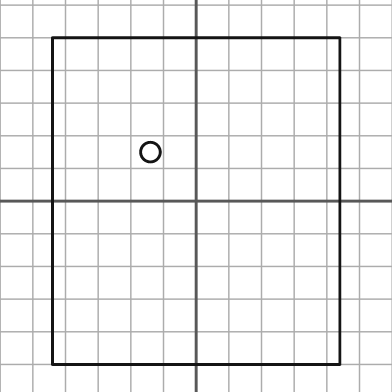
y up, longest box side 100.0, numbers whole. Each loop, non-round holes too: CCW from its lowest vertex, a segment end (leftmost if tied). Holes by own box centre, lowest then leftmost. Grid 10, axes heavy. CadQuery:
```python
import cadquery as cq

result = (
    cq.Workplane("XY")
    .moveTo(-44.0, -50.0)
    .lineTo(44.0, -50.0)
    .lineTo(44.0, 50.0)
    .lineTo(-44.0, 50.0)
    .close()
    .moveTo(-14.0, 15.0)
    .circle(3.0)
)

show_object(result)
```